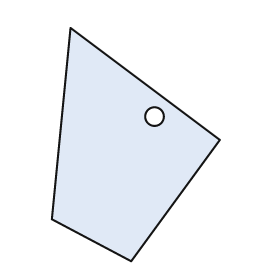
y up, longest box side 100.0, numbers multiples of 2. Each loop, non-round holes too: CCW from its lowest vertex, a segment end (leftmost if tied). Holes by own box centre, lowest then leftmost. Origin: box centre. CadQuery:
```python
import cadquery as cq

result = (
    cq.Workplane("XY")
    .moveTo(-2.0, -50.0)
    .lineTo(36.0, 2.0)
    .lineTo(-28.0, 50.0)
    .lineTo(-36.0, -32.0)
    .close()
    .moveTo(8.0, 12.0)
    .circle(4.0)
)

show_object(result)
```